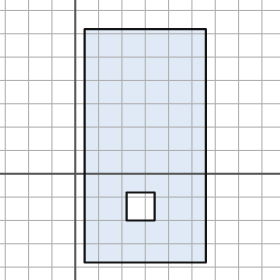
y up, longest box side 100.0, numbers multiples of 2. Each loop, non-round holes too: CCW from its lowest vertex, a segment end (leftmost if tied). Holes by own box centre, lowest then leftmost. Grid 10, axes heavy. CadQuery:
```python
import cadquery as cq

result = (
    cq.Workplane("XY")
    .moveTo(4.0, -38.0)
    .lineTo(56.0, -38.0)
    .lineTo(56.0, 62.0)
    .lineTo(4.0, 62.0)
    .close()
    .moveTo(22.0, -20.0)
    .lineTo(34.0, -20.0)
    .lineTo(34.0, -8.0)
    .lineTo(22.0, -8.0)
    .close()
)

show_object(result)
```